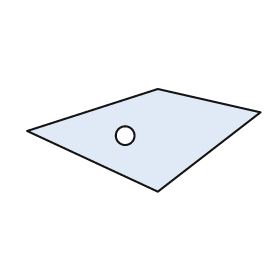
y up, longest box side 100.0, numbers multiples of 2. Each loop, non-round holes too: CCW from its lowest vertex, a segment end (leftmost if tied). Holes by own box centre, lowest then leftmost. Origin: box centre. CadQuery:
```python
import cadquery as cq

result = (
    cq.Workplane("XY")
    .moveTo(6.0, -22.0)
    .lineTo(50.0, 12.0)
    .lineTo(6.0, 22.0)
    .lineTo(-50.0, 4.0)
    .close()
    .moveTo(-8.0, 2.0)
    .circle(4.0)
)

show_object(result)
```